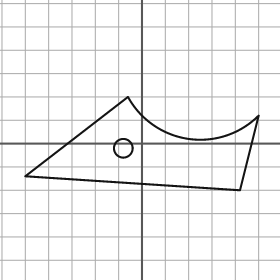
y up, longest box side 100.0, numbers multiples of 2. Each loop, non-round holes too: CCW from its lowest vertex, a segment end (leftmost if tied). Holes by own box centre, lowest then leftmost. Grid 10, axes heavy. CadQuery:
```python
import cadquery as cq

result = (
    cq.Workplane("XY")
    .moveTo(42.0, -20.0)
    .lineTo(50.0, 12.0)
    .threePointArc((20.0, 2.0), (-6.0, 20.0))
    .lineTo(-50.0, -14.0)
    .close()
    .moveTo(-8.0, -2.0)
    .circle(4.0)
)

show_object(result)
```